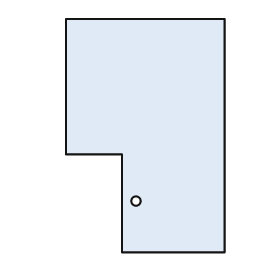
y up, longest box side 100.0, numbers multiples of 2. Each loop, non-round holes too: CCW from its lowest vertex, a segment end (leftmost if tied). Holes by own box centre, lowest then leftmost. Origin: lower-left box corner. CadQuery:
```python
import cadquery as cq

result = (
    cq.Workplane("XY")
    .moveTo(24.0, 0.0)
    .lineTo(68.0, 0.0)
    .lineTo(68.0, 100.0)
    .lineTo(0.0, 100.0)
    .lineTo(0.0, 42.0)
    .lineTo(24.0, 42.0)
    .close()
    .moveTo(30.0, 22.0)
    .circle(2.0)
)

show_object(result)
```